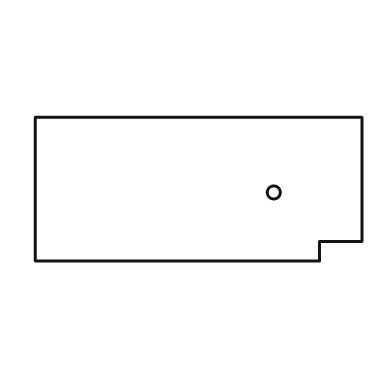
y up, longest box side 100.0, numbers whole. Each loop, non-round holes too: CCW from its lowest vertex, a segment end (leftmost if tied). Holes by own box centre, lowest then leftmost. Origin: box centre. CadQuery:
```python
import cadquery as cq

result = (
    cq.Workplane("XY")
    .moveTo(-50.0, -22.0)
    .lineTo(37.0, -22.0)
    .lineTo(37.0, -16.0)
    .lineTo(50.0, -16.0)
    .lineTo(50.0, 22.0)
    .lineTo(-50.0, 22.0)
    .close()
    .moveTo(23.0, -1.0)
    .circle(2.0)
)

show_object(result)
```